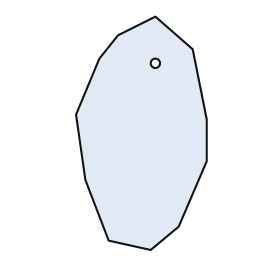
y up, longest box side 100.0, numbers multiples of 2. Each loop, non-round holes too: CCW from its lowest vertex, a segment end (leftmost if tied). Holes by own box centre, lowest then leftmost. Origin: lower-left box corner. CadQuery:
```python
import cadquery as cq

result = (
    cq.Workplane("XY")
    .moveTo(32.0, 0.0)
    .lineTo(44.0, 10.0)
    .lineTo(56.0, 38.0)
    .lineTo(56.0, 56.0)
    .lineTo(50.0, 86.0)
    .lineTo(34.0, 100.0)
    .lineTo(18.0, 92.0)
    .lineTo(10.0, 82.0)
    .lineTo(0.0, 58.0)
    .lineTo(4.0, 30.0)
    .lineTo(14.0, 4.0)
    .close()
    .moveTo(34.0, 80.0)
    .circle(2.0)
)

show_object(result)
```